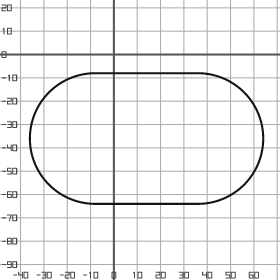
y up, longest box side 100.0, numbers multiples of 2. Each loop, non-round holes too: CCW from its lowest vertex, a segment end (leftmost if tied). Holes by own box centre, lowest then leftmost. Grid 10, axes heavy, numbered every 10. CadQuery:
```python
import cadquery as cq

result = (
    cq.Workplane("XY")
    .moveTo(-8.0, -64.0)
    .lineTo(36.0, -64.0)
    .threePointArc((64.0, -36.0), (36.0, -8.0))
    .lineTo(-8.0, -8.0)
    .threePointArc((-36.0, -36.0), (-8.0, -64.0))
    .close()
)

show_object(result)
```